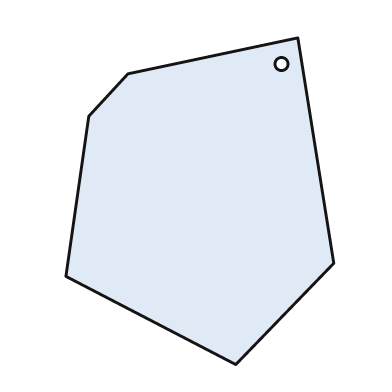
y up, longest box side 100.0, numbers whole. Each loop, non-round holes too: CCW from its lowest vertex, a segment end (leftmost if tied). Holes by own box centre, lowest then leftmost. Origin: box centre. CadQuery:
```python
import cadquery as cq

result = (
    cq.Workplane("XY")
    .moveTo(11.0, -50.0)
    .lineTo(41.0, -19.0)
    .lineTo(30.0, 50.0)
    .lineTo(-22.0, 39.0)
    .lineTo(-34.0, 26.0)
    .lineTo(-41.0, -23.0)
    .close()
    .moveTo(25.0, 42.0)
    .circle(2.0)
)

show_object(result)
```